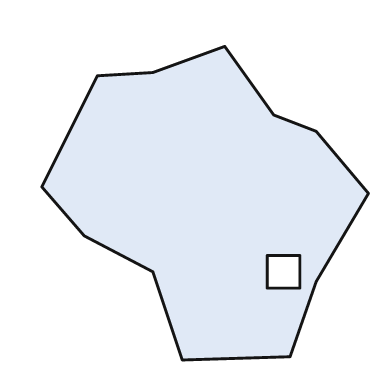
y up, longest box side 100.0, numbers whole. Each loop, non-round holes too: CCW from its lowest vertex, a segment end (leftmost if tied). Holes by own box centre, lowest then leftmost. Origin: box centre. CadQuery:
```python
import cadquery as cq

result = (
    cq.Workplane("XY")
    .moveTo(-7.0, -48.0)
    .lineTo(26.0, -47.0)
    .lineTo(34.0, -24.0)
    .lineTo(50.0, 3.0)
    .lineTo(34.0, 22.0)
    .lineTo(21.0, 27.0)
    .lineTo(6.0, 48.0)
    .lineTo(-16.0, 40.0)
    .lineTo(-33.0, 39.0)
    .lineTo(-50.0, 5.0)
    .lineTo(-37.0, -10.0)
    .lineTo(-16.0, -21.0)
    .close()
    .moveTo(19.0, -26.0)
    .lineTo(29.0, -26.0)
    .lineTo(29.0, -16.0)
    .lineTo(19.0, -16.0)
    .close()
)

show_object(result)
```